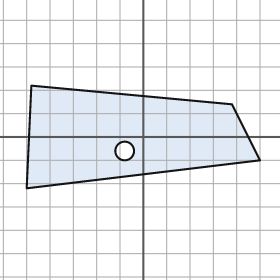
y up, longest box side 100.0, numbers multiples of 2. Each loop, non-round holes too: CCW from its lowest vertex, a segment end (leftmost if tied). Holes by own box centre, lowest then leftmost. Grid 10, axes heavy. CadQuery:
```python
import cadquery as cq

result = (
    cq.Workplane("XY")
    .moveTo(-50.0, -22.0)
    .lineTo(50.0, -10.0)
    .lineTo(38.0, 14.0)
    .lineTo(-48.0, 22.0)
    .close()
    .moveTo(-8.0, -6.0)
    .circle(4.0)
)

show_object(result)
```